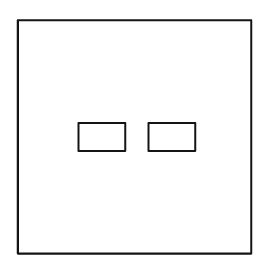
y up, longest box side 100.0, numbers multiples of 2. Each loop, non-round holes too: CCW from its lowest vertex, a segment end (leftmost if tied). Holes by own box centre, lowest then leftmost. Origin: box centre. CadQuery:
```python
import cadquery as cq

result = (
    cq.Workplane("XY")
    .moveTo(-50.0, -50.0)
    .lineTo(50.0, -50.0)
    .lineTo(50.0, 50.0)
    .lineTo(-50.0, 50.0)
    .close()
    .moveTo(-24.0, -6.0)
    .lineTo(-4.0, -6.0)
    .lineTo(-4.0, 6.0)
    .lineTo(-24.0, 6.0)
    .close()
    .moveTo(6.0, -6.0)
    .lineTo(26.0, -6.0)
    .lineTo(26.0, 6.0)
    .lineTo(6.0, 6.0)
    .close()
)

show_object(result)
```